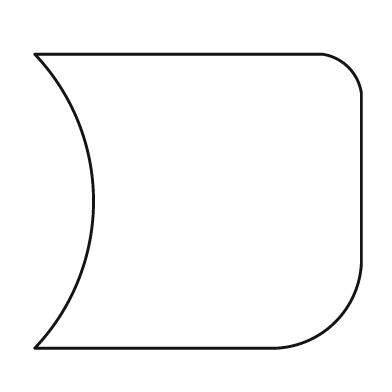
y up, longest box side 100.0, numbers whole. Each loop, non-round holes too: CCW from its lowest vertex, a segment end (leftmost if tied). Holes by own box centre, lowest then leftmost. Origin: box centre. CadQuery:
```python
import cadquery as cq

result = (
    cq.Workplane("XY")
    .moveTo(-50.0, -45.0)
    .lineTo(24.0, -45.0)
    .threePointArc((42.0, -37.0), (50.0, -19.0))
    .lineTo(50.0, 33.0)
    .threePointArc((46.0, 41.0), (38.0, 45.0))
    .lineTo(-50.0, 45.0)
    .threePointArc((-32.0, 0.0), (-50.0, -45.0))
    .close()
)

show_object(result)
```